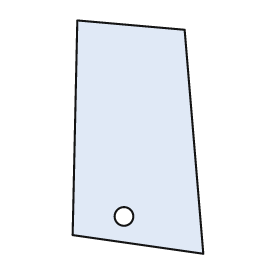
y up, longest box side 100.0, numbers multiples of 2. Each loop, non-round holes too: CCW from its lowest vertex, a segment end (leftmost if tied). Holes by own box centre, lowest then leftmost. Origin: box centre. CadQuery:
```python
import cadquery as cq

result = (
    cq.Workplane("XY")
    .moveTo(28.0, -50.0)
    .lineTo(20.0, 46.0)
    .lineTo(-26.0, 50.0)
    .lineTo(-28.0, -42.0)
    .close()
    .moveTo(-6.0, -34.0)
    .circle(4.0)
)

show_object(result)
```